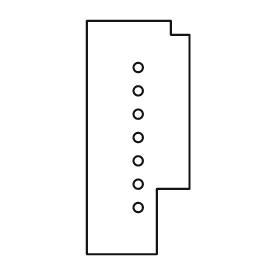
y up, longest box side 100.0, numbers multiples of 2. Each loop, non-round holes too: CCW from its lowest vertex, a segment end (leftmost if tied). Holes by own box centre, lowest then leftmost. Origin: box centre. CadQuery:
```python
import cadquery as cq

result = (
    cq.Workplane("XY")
    .moveTo(-22.0, -50.0)
    .lineTo(8.0, -50.0)
    .lineTo(8.0, -22.0)
    .lineTo(22.0, -22.0)
    .lineTo(22.0, 44.0)
    .lineTo(14.0, 44.0)
    .lineTo(14.0, 50.0)
    .lineTo(-22.0, 50.0)
    .close()
    .moveTo(0.0, -30.0)
    .circle(2.0)
    .moveTo(0.0, -20.0)
    .circle(2.0)
    .moveTo(0.0, -10.0)
    .circle(2.0)
    .moveTo(0.0, 0.0)
    .circle(2.0)
    .moveTo(0.0, 10.0)
    .circle(2.0)
    .moveTo(0.0, 20.0)
    .circle(2.0)
    .moveTo(0.0, 30.0)
    .circle(2.0)
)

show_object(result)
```